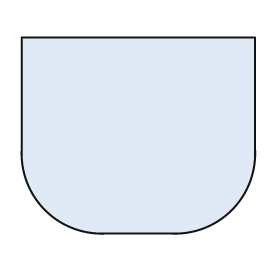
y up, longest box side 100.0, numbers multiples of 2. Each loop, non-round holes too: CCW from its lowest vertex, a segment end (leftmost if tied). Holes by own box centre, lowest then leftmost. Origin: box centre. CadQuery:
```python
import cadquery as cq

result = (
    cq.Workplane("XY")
    .moveTo(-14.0, -42.0)
    .lineTo(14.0, -42.0)
    .threePointArc((40.0, -32.0), (50.0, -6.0))
    .lineTo(50.0, 42.0)
    .lineTo(-50.0, 42.0)
    .lineTo(-50.0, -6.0)
    .threePointArc((-40.0, -32.0), (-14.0, -42.0))
    .close()
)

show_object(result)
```